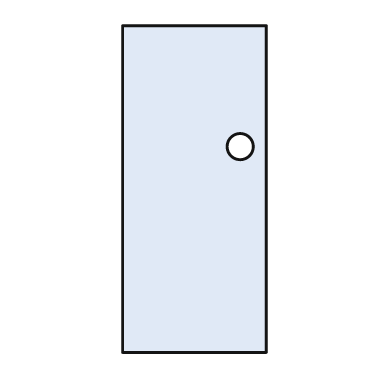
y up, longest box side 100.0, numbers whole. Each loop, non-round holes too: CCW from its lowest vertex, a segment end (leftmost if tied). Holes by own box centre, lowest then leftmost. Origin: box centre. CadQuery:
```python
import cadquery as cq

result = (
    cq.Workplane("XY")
    .moveTo(-22.0, -50.0)
    .lineTo(22.0, -50.0)
    .lineTo(22.0, 50.0)
    .lineTo(-22.0, 50.0)
    .close()
    .moveTo(14.0, 13.0)
    .circle(4.0)
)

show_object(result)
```